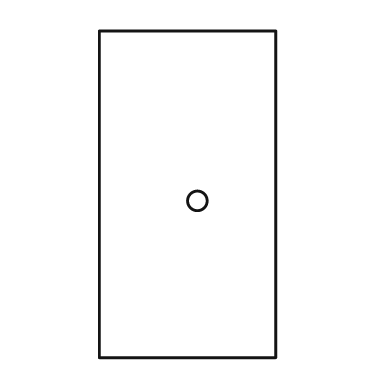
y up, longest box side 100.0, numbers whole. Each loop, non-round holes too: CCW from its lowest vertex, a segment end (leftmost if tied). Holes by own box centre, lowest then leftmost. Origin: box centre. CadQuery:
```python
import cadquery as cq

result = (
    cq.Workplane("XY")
    .moveTo(-27.0, -50.0)
    .lineTo(27.0, -50.0)
    .lineTo(27.0, 50.0)
    .lineTo(-27.0, 50.0)
    .close()
    .moveTo(3.0, -2.0)
    .circle(3.0)
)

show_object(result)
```